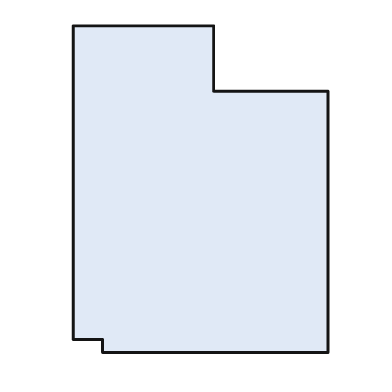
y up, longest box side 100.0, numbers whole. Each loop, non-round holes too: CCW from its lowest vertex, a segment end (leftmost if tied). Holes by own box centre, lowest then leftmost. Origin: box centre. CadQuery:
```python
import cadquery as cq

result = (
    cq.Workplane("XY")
    .moveTo(-30.0, -50.0)
    .lineTo(39.0, -50.0)
    .lineTo(39.0, 30.0)
    .lineTo(4.0, 30.0)
    .lineTo(4.0, 50.0)
    .lineTo(-39.0, 50.0)
    .lineTo(-39.0, -46.0)
    .lineTo(-30.0, -46.0)
    .close()
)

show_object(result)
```